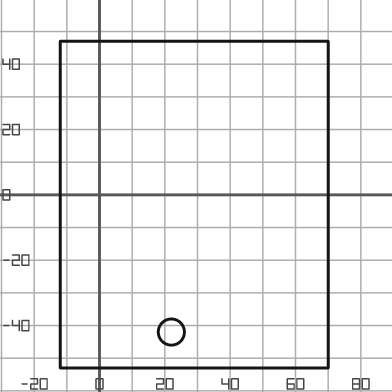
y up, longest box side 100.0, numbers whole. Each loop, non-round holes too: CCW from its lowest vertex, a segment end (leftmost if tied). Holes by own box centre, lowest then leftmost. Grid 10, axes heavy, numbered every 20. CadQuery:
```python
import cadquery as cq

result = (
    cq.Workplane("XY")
    .moveTo(-12.0, -53.0)
    .lineTo(70.0, -53.0)
    .lineTo(70.0, 47.0)
    .lineTo(-12.0, 47.0)
    .close()
    .moveTo(22.0, -42.0)
    .circle(4.0)
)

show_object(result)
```